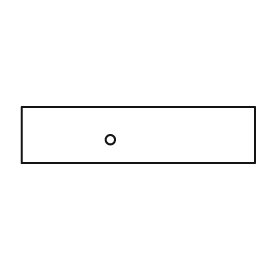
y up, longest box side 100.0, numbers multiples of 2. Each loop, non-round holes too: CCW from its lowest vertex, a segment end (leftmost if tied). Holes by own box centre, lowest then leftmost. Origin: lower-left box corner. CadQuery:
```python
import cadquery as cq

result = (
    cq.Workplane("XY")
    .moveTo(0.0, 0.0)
    .lineTo(100.0, 0.0)
    .lineTo(100.0, 24.0)
    .lineTo(0.0, 24.0)
    .close()
    .moveTo(38.0, 10.0)
    .circle(2.0)
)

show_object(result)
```